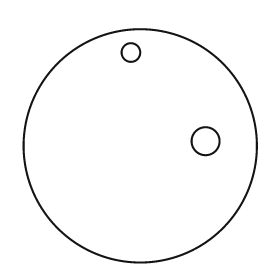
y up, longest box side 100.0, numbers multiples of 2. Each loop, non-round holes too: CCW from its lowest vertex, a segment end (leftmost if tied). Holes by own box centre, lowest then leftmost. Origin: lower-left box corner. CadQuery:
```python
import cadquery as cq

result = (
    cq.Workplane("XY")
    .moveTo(50.0, 50.0)
    .circle(50.0)
    .moveTo(78.0, 52.0)
    .circle(6.0)
    .moveTo(46.0, 90.0)
    .circle(4.0)
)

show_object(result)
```